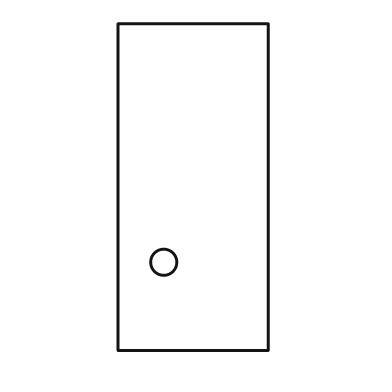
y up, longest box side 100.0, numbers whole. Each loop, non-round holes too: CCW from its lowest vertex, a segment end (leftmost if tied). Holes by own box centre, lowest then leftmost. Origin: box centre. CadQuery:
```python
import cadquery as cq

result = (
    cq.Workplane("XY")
    .moveTo(-23.0, -50.0)
    .lineTo(23.0, -50.0)
    .lineTo(23.0, 50.0)
    .lineTo(-23.0, 50.0)
    .close()
    .moveTo(-9.0, -23.0)
    .circle(4.0)
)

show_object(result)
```